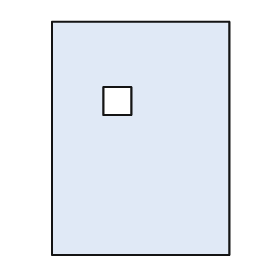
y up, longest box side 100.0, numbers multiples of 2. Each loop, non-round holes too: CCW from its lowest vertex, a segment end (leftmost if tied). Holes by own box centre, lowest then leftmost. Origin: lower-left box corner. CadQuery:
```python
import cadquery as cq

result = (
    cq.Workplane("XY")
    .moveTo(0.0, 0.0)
    .lineTo(76.0, 0.0)
    .lineTo(76.0, 100.0)
    .lineTo(0.0, 100.0)
    .close()
    .moveTo(22.0, 60.0)
    .lineTo(34.0, 60.0)
    .lineTo(34.0, 72.0)
    .lineTo(22.0, 72.0)
    .close()
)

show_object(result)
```